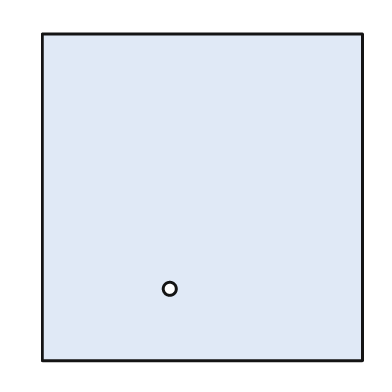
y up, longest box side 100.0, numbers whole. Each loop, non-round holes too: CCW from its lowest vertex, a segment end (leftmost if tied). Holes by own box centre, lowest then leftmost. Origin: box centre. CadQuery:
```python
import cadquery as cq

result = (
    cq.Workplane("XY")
    .moveTo(-49.0, -50.0)
    .lineTo(49.0, -50.0)
    .lineTo(49.0, 50.0)
    .lineTo(-49.0, 50.0)
    .close()
    .moveTo(-10.0, -28.0)
    .circle(2.0)
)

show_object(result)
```